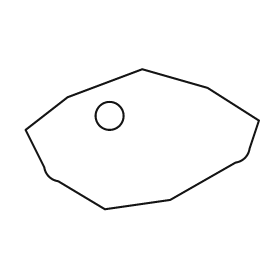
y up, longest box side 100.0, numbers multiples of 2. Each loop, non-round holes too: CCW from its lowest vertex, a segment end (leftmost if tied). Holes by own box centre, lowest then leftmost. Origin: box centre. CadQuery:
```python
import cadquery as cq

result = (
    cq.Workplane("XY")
    .moveTo(-16.0, -30.0)
    .lineTo(12.0, -26.0)
    .lineTo(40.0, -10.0)
    .threePointArc((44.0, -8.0), (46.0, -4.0))
    .lineTo(50.0, 8.0)
    .lineTo(28.0, 22.0)
    .lineTo(0.0, 30.0)
    .lineTo(-32.0, 18.0)
    .lineTo(-50.0, 4.0)
    .lineTo(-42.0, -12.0)
    .threePointArc((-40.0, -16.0), (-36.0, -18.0))
    .close()
    .moveTo(-14.0, 10.0)
    .circle(6.0)
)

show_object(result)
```